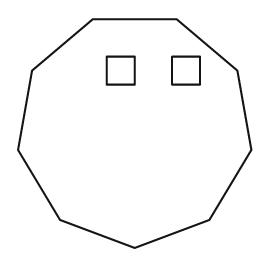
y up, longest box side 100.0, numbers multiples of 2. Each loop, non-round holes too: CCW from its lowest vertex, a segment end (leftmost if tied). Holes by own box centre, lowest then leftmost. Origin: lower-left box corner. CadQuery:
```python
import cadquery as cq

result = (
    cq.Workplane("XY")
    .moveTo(50.0, 0.0)
    .lineTo(82.0, 12.0)
    .lineTo(100.0, 42.0)
    .lineTo(94.0, 76.0)
    .lineTo(68.0, 98.0)
    .lineTo(32.0, 98.0)
    .lineTo(6.0, 76.0)
    .lineTo(0.0, 42.0)
    .lineTo(18.0, 12.0)
    .close()
    .moveTo(38.0, 70.0)
    .lineTo(50.0, 70.0)
    .lineTo(50.0, 82.0)
    .lineTo(38.0, 82.0)
    .close()
    .moveTo(66.0, 70.0)
    .lineTo(78.0, 70.0)
    .lineTo(78.0, 82.0)
    .lineTo(66.0, 82.0)
    .close()
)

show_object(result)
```